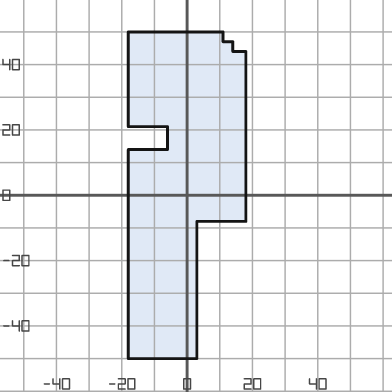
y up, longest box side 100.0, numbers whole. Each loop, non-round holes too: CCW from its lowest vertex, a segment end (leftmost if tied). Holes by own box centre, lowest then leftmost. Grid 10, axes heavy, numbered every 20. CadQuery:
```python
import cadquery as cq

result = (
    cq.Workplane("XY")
    .moveTo(-18.0, -50.0)
    .lineTo(3.0, -50.0)
    .lineTo(3.0, -8.0)
    .lineTo(18.0, -8.0)
    .lineTo(18.0, 44.0)
    .lineTo(14.0, 44.0)
    .lineTo(14.0, 47.0)
    .lineTo(11.0, 47.0)
    .lineTo(11.0, 50.0)
    .lineTo(-18.0, 50.0)
    .lineTo(-18.0, 21.0)
    .lineTo(-6.0, 21.0)
    .lineTo(-6.0, 14.0)
    .lineTo(-18.0, 14.0)
    .close()
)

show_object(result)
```